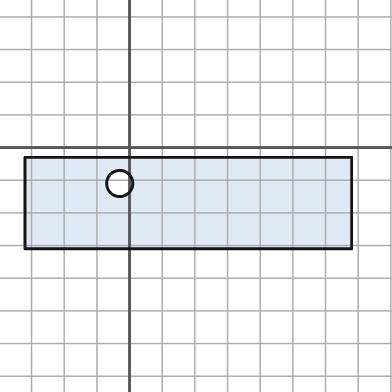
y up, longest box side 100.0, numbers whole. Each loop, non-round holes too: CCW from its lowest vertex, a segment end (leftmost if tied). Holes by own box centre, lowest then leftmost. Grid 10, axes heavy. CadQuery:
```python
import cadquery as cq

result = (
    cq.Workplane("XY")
    .moveTo(-32.0, -31.0)
    .lineTo(68.0, -31.0)
    .lineTo(68.0, -3.0)
    .lineTo(-32.0, -3.0)
    .close()
    .moveTo(-3.0, -11.0)
    .circle(4.0)
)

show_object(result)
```